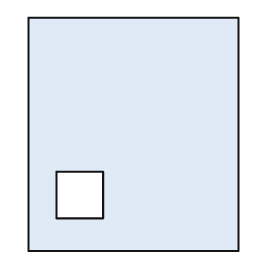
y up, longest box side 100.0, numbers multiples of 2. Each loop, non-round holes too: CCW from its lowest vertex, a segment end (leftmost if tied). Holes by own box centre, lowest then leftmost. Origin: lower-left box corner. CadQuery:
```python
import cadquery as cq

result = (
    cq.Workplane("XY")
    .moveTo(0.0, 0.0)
    .lineTo(90.0, 0.0)
    .lineTo(90.0, 100.0)
    .lineTo(0.0, 100.0)
    .close()
    .moveTo(12.0, 14.0)
    .lineTo(32.0, 14.0)
    .lineTo(32.0, 34.0)
    .lineTo(12.0, 34.0)
    .close()
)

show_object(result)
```